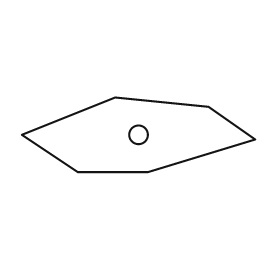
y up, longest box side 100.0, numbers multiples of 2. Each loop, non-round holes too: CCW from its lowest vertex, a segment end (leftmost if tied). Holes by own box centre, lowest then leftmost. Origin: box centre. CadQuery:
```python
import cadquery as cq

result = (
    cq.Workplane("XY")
    .moveTo(-26.0, -16.0)
    .lineTo(4.0, -16.0)
    .lineTo(50.0, -2.0)
    .lineTo(30.0, 12.0)
    .lineTo(-10.0, 16.0)
    .lineTo(-50.0, 0.0)
    .close()
    .moveTo(0.0, 0.0)
    .circle(4.0)
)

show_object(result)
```